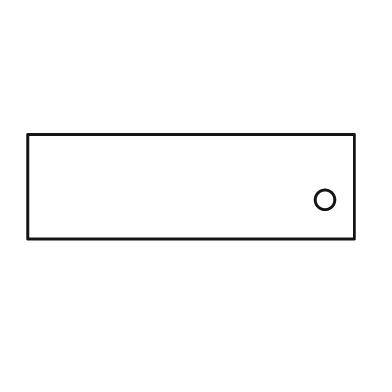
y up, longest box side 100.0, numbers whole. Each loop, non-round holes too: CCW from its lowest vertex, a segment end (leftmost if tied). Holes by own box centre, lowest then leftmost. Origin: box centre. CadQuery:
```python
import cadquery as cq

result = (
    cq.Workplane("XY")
    .moveTo(-50.0, -16.0)
    .lineTo(50.0, -16.0)
    .lineTo(50.0, 16.0)
    .lineTo(-50.0, 16.0)
    .close()
    .moveTo(41.0, -4.0)
    .circle(3.0)
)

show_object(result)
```